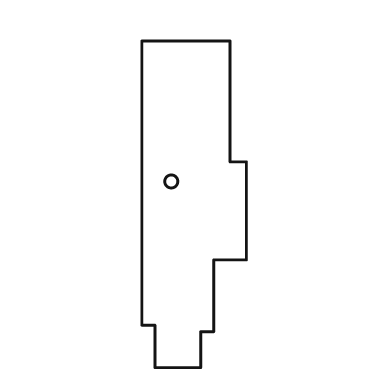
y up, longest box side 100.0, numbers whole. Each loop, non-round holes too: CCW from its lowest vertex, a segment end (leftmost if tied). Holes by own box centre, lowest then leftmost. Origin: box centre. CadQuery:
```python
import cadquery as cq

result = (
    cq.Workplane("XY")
    .moveTo(-12.0, -50.0)
    .lineTo(2.0, -50.0)
    .lineTo(2.0, -39.0)
    .lineTo(6.0, -39.0)
    .lineTo(6.0, -17.0)
    .lineTo(16.0, -17.0)
    .lineTo(16.0, 13.0)
    .lineTo(11.0, 13.0)
    .lineTo(11.0, 50.0)
    .lineTo(-16.0, 50.0)
    .lineTo(-16.0, -37.0)
    .lineTo(-12.0, -37.0)
    .close()
    .moveTo(-7.0, 7.0)
    .circle(2.0)
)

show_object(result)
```